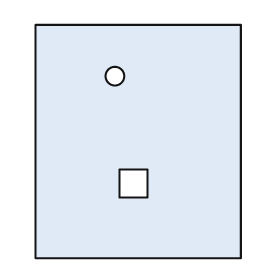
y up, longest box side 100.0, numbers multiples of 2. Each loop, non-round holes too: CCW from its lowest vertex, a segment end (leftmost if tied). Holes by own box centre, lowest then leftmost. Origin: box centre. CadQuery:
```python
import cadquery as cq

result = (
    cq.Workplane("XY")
    .moveTo(-44.0, -50.0)
    .lineTo(44.0, -50.0)
    .lineTo(44.0, 50.0)
    .lineTo(-44.0, 50.0)
    .close()
    .moveTo(-8.0, -24.0)
    .lineTo(4.0, -24.0)
    .lineTo(4.0, -12.0)
    .lineTo(-8.0, -12.0)
    .close()
    .moveTo(-10.0, 28.0)
    .circle(4.0)
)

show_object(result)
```